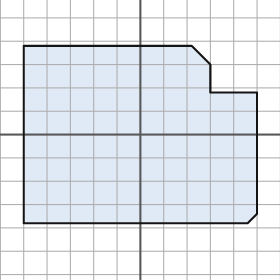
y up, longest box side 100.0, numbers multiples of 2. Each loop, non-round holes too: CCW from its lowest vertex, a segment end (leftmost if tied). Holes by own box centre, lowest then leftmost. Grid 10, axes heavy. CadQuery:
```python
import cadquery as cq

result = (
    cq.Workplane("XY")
    .moveTo(-50.0, -38.0)
    .lineTo(46.0, -38.0)
    .lineTo(50.0, -34.0)
    .lineTo(50.0, 18.0)
    .lineTo(30.0, 18.0)
    .lineTo(30.0, 30.0)
    .lineTo(22.0, 38.0)
    .lineTo(-50.0, 38.0)
    .close()
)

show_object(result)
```